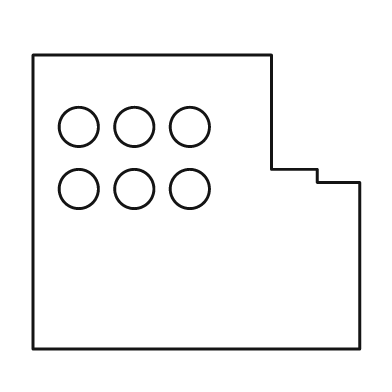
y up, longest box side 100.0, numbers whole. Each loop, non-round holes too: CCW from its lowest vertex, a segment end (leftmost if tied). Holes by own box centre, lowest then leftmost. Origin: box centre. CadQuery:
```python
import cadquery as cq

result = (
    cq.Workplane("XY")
    .moveTo(-50.0, -45.0)
    .lineTo(50.0, -45.0)
    .lineTo(50.0, 6.0)
    .lineTo(37.0, 6.0)
    .lineTo(37.0, 10.0)
    .lineTo(23.0, 10.0)
    .lineTo(23.0, 45.0)
    .lineTo(-50.0, 45.0)
    .close()
    .moveTo(-36.0, 4.0)
    .circle(6.0)
    .moveTo(-19.0, 4.0)
    .circle(6.0)
    .moveTo(-2.0, 4.0)
    .circle(6.0)
    .moveTo(-36.0, 23.0)
    .circle(6.0)
    .moveTo(-19.0, 23.0)
    .circle(6.0)
    .moveTo(-2.0, 23.0)
    .circle(6.0)
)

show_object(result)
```